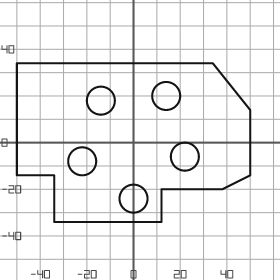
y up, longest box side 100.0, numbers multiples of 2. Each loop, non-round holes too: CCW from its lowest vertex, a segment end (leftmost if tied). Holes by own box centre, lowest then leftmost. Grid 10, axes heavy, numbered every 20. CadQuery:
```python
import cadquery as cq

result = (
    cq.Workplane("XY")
    .moveTo(-34.0, -34.0)
    .lineTo(12.0, -34.0)
    .lineTo(12.0, -20.0)
    .lineTo(38.0, -20.0)
    .lineTo(50.0, -14.0)
    .lineTo(50.0, 14.0)
    .lineTo(34.0, 34.0)
    .lineTo(-50.0, 34.0)
    .lineTo(-50.0, -14.0)
    .lineTo(-34.0, -14.0)
    .close()
    .moveTo(0.0, -24.0)
    .circle(6.0)
    .moveTo(-22.0, -8.0)
    .circle(6.0)
    .moveTo(22.0, -6.0)
    .circle(6.0)
    .moveTo(-14.0, 18.0)
    .circle(6.0)
    .moveTo(14.0, 20.0)
    .circle(6.0)
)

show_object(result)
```